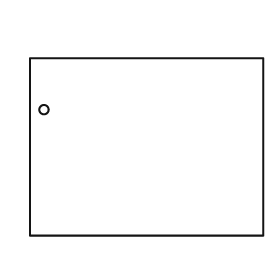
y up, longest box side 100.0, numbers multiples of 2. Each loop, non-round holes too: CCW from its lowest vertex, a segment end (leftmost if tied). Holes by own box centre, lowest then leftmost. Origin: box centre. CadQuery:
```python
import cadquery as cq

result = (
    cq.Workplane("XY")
    .moveTo(-50.0, -38.0)
    .lineTo(50.0, -38.0)
    .lineTo(50.0, 38.0)
    .lineTo(-50.0, 38.0)
    .close()
    .moveTo(-44.0, 16.0)
    .circle(2.0)
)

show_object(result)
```